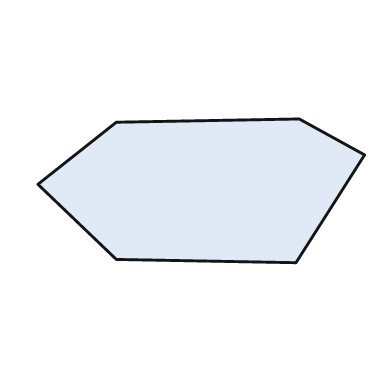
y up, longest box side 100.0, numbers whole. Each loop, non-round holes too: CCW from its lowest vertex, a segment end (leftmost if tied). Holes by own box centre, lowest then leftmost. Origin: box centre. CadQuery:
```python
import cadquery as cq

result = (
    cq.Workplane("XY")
    .moveTo(29.0, -22.0)
    .lineTo(50.0, 11.0)
    .lineTo(30.0, 22.0)
    .lineTo(-26.0, 21.0)
    .lineTo(-50.0, 2.0)
    .lineTo(-26.0, -21.0)
    .close()
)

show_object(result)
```